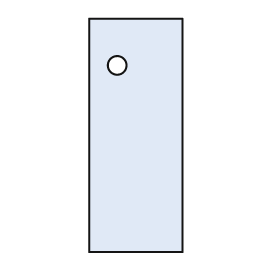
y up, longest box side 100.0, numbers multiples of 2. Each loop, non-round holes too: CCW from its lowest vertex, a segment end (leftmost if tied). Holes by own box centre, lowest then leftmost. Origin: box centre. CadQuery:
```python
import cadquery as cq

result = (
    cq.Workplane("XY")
    .moveTo(-20.0, -50.0)
    .lineTo(20.0, -50.0)
    .lineTo(20.0, 50.0)
    .lineTo(-20.0, 50.0)
    .close()
    .moveTo(-8.0, 30.0)
    .circle(4.0)
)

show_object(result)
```